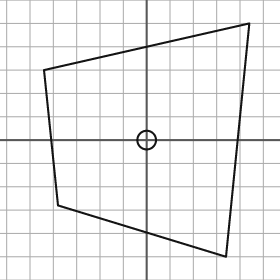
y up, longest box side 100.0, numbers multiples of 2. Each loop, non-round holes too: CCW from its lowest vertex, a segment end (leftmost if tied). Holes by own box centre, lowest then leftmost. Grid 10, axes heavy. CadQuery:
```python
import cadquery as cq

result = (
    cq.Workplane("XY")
    .moveTo(34.0, -50.0)
    .lineTo(44.0, 50.0)
    .lineTo(-44.0, 30.0)
    .lineTo(-38.0, -28.0)
    .close()
    .moveTo(0.0, 0.0)
    .circle(4.0)
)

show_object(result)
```